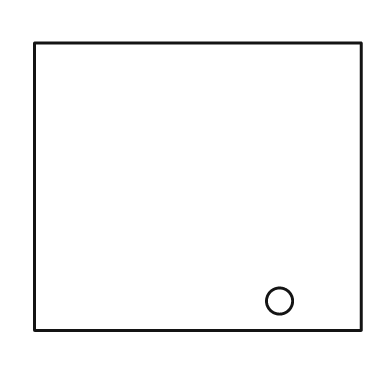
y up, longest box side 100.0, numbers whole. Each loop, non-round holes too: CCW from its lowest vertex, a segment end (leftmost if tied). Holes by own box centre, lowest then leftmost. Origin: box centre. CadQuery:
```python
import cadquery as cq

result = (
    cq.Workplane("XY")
    .moveTo(-50.0, -44.0)
    .lineTo(50.0, -44.0)
    .lineTo(50.0, 44.0)
    .lineTo(-50.0, 44.0)
    .close()
    .moveTo(25.0, -35.0)
    .circle(4.0)
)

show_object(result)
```